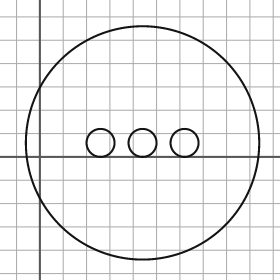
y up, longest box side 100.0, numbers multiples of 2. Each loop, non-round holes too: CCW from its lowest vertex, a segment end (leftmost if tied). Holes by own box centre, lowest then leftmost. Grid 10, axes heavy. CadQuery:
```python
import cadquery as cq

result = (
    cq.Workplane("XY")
    .moveTo(44.0, 6.0)
    .circle(50.0)
    .moveTo(26.0, 6.0)
    .circle(6.0)
    .moveTo(44.0, 6.0)
    .circle(6.0)
    .moveTo(62.0, 6.0)
    .circle(6.0)
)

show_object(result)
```